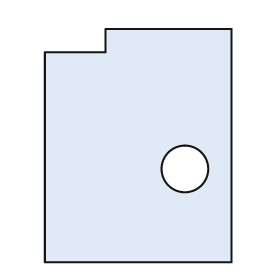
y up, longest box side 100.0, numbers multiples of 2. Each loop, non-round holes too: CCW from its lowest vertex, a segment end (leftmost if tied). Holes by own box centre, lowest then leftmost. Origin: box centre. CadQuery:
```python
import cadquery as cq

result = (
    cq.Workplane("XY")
    .moveTo(-40.0, -50.0)
    .lineTo(40.0, -50.0)
    .lineTo(40.0, 50.0)
    .lineTo(-14.0, 50.0)
    .lineTo(-14.0, 40.0)
    .lineTo(-40.0, 40.0)
    .close()
    .moveTo(20.0, -10.0)
    .circle(10.0)
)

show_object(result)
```